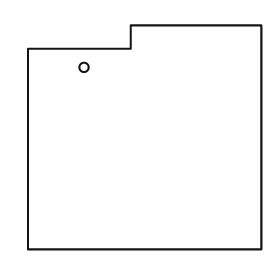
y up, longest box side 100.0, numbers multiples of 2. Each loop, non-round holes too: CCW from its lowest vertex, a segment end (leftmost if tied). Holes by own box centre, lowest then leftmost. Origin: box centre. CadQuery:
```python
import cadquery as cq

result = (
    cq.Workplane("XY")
    .moveTo(-50.0, -48.0)
    .lineTo(50.0, -48.0)
    .lineTo(50.0, 48.0)
    .lineTo(-6.0, 48.0)
    .lineTo(-6.0, 38.0)
    .lineTo(-50.0, 38.0)
    .close()
    .moveTo(-26.0, 30.0)
    .circle(2.0)
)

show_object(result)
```